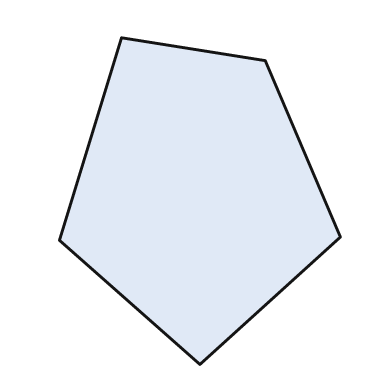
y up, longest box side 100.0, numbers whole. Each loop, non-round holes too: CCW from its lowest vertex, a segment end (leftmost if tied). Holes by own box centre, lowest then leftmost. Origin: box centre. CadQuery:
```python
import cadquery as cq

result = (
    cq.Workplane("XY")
    .moveTo(0.0, -50.0)
    .lineTo(43.0, -11.0)
    .lineTo(20.0, 43.0)
    .lineTo(-24.0, 50.0)
    .lineTo(-43.0, -12.0)
    .close()
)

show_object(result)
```